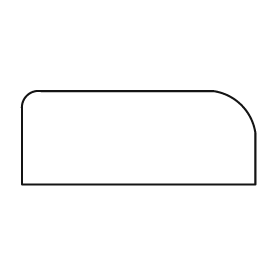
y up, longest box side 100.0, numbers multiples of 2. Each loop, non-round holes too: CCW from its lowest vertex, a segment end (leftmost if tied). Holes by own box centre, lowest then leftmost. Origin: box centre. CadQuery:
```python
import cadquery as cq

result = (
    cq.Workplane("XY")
    .moveTo(-50.0, -20.0)
    .lineTo(50.0, -20.0)
    .lineTo(50.0, 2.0)
    .threePointArc((44.0, 14.0), (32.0, 20.0))
    .lineTo(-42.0, 20.0)
    .threePointArc((-48.0, 18.0), (-50.0, 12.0))
    .close()
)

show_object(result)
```